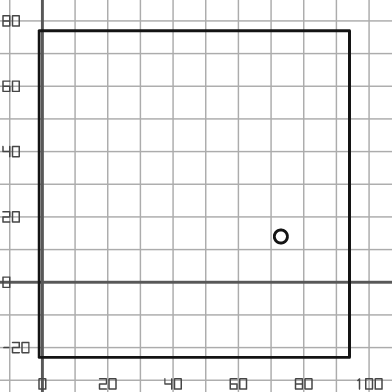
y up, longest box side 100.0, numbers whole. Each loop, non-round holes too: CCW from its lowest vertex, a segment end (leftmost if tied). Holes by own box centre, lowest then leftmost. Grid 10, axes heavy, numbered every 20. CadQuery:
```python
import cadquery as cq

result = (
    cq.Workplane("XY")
    .moveTo(-1.0, -23.0)
    .lineTo(94.0, -23.0)
    .lineTo(94.0, 77.0)
    .lineTo(-1.0, 77.0)
    .close()
    .moveTo(73.0, 14.0)
    .circle(2.0)
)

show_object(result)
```